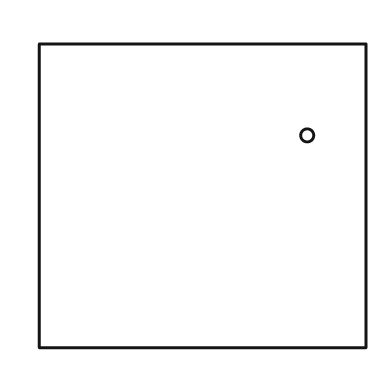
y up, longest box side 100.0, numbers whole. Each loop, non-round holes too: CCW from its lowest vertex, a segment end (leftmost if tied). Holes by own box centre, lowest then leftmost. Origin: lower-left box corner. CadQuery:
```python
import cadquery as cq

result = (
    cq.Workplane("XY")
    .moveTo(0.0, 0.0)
    .lineTo(100.0, 0.0)
    .lineTo(100.0, 93.0)
    .lineTo(0.0, 93.0)
    .close()
    .moveTo(82.0, 65.0)
    .circle(2.0)
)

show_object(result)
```